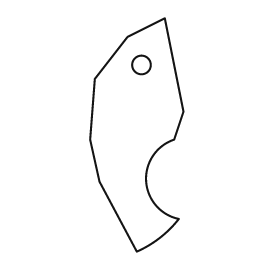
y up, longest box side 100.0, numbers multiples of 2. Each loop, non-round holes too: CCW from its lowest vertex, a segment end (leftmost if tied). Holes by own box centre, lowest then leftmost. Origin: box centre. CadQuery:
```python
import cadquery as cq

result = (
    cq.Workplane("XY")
    .moveTo(0.0, -50.0)
    .threePointArc((10.0, -44.0), (18.0, -36.0))
    .threePointArc((4.0, -20.0), (16.0, -2.0))
    .lineTo(20.0, 10.0)
    .lineTo(12.0, 50.0)
    .lineTo(-4.0, 42.0)
    .lineTo(-18.0, 24.0)
    .lineTo(-20.0, -2.0)
    .lineTo(-16.0, -20.0)
    .close()
    .moveTo(2.0, 30.0)
    .circle(4.0)
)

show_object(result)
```